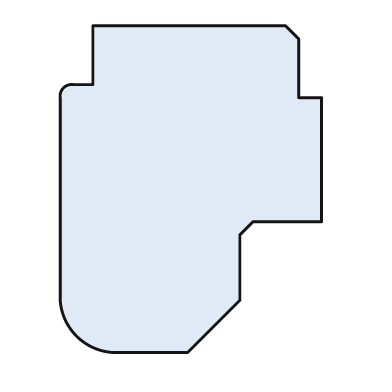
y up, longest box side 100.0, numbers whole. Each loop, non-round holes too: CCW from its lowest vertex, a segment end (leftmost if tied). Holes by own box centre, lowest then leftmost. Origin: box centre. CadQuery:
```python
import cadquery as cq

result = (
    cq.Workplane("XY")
    .moveTo(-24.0, -50.0)
    .lineTo(-1.0, -50.0)
    .lineTo(15.0, -34.0)
    .lineTo(15.0, -14.0)
    .lineTo(19.0, -10.0)
    .lineTo(40.0, -10.0)
    .lineTo(40.0, 28.0)
    .lineTo(33.0, 28.0)
    .lineTo(33.0, 46.0)
    .lineTo(29.0, 50.0)
    .lineTo(-30.0, 50.0)
    .lineTo(-30.0, 32.0)
    .lineTo(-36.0, 32.0)
    .threePointArc((-39.0, 31.0), (-40.0, 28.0))
    .lineTo(-40.0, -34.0)
    .threePointArc((-35.0, -45.0), (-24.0, -50.0))
    .close()
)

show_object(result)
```